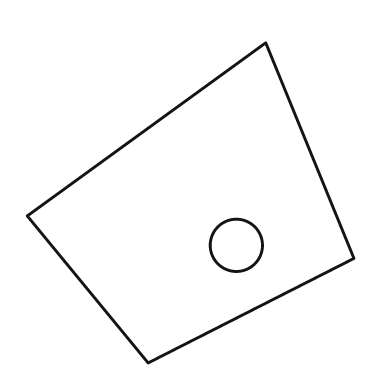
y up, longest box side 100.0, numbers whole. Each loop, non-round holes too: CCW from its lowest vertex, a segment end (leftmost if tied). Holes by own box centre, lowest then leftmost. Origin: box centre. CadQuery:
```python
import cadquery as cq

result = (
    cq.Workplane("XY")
    .moveTo(-13.0, -49.0)
    .lineTo(50.0, -17.0)
    .lineTo(23.0, 49.0)
    .lineTo(-50.0, -4.0)
    .close()
    .moveTo(14.0, -13.0)
    .circle(8.0)
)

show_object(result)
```